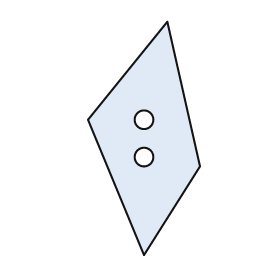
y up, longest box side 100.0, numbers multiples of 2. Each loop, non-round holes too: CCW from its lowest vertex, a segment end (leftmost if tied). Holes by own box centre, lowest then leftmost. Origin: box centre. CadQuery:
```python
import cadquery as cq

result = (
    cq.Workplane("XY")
    .moveTo(0.0, -50.0)
    .lineTo(24.0, -12.0)
    .lineTo(10.0, 50.0)
    .lineTo(-24.0, 8.0)
    .close()
    .moveTo(0.0, -8.0)
    .circle(4.0)
    .moveTo(0.0, 8.0)
    .circle(4.0)
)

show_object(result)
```